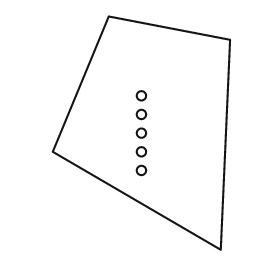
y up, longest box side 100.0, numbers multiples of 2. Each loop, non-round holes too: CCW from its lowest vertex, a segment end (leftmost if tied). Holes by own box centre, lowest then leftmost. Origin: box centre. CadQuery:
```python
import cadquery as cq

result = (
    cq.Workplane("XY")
    .moveTo(34.0, -50.0)
    .lineTo(38.0, 40.0)
    .lineTo(-14.0, 50.0)
    .lineTo(-38.0, -8.0)
    .close()
    .moveTo(0.0, -16.0)
    .circle(2.0)
    .moveTo(0.0, -8.0)
    .circle(2.0)
    .moveTo(0.0, 0.0)
    .circle(2.0)
    .moveTo(0.0, 8.0)
    .circle(2.0)
    .moveTo(0.0, 16.0)
    .circle(2.0)
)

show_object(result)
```